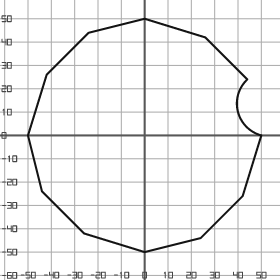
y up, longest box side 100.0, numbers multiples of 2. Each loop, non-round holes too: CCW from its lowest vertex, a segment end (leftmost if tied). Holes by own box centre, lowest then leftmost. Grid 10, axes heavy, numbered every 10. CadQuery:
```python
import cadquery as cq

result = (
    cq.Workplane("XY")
    .moveTo(0.0, -50.0)
    .lineTo(24.0, -44.0)
    .lineTo(42.0, -26.0)
    .lineTo(50.0, 0.0)
    .threePointArc((40.0, 10.0), (44.0, 24.0))
    .lineTo(26.0, 42.0)
    .lineTo(0.0, 50.0)
    .lineTo(-24.0, 44.0)
    .lineTo(-42.0, 26.0)
    .lineTo(-50.0, 0.0)
    .lineTo(-44.0, -24.0)
    .lineTo(-26.0, -42.0)
    .close()
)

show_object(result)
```